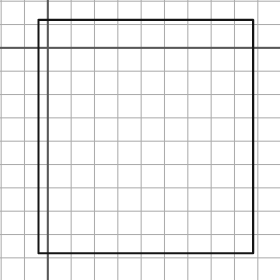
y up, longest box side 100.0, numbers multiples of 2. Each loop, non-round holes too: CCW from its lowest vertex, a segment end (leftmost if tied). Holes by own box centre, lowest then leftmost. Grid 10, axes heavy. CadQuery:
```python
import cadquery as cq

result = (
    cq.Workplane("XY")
    .moveTo(-4.0, -88.0)
    .lineTo(88.0, -88.0)
    .lineTo(88.0, 12.0)
    .lineTo(-4.0, 12.0)
    .close()
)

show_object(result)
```